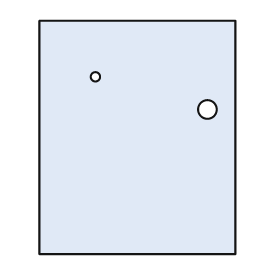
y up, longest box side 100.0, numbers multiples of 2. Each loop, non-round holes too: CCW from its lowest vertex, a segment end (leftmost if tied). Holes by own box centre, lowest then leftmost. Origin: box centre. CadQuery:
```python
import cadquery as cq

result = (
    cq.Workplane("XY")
    .moveTo(-42.0, -50.0)
    .lineTo(42.0, -50.0)
    .lineTo(42.0, 50.0)
    .lineTo(-42.0, 50.0)
    .close()
    .moveTo(30.0, 12.0)
    .circle(4.0)
    .moveTo(-18.0, 26.0)
    .circle(2.0)
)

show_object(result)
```